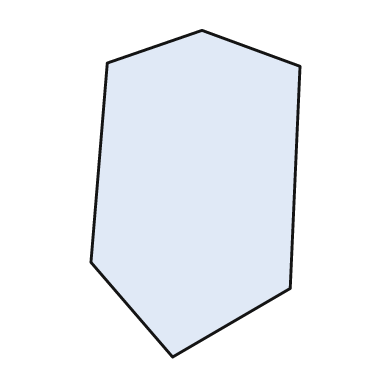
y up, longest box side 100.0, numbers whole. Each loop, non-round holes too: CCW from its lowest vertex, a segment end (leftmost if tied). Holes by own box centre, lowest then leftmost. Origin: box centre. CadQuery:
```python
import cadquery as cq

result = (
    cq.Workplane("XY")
    .moveTo(-7.0, -50.0)
    .lineTo(29.0, -29.0)
    .lineTo(32.0, 39.0)
    .lineTo(2.0, 50.0)
    .lineTo(-27.0, 40.0)
    .lineTo(-32.0, -21.0)
    .close()
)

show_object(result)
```